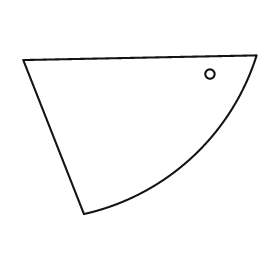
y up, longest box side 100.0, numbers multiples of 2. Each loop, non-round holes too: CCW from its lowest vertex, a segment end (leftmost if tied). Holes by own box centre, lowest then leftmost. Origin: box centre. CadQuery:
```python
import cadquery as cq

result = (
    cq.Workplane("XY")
    .moveTo(-24.0, -34.0)
    .threePointArc((22.0, -10.0), (50.0, 34.0))
    .lineTo(-50.0, 32.0)
    .close()
    .moveTo(30.0, 26.0)
    .circle(2.0)
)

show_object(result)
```